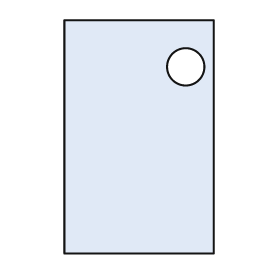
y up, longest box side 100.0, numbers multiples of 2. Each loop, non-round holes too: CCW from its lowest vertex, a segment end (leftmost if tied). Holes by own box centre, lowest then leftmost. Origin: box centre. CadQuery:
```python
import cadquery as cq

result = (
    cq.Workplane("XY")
    .moveTo(-32.0, -50.0)
    .lineTo(32.0, -50.0)
    .lineTo(32.0, 50.0)
    .lineTo(-32.0, 50.0)
    .close()
    .moveTo(20.0, 30.0)
    .circle(8.0)
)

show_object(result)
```